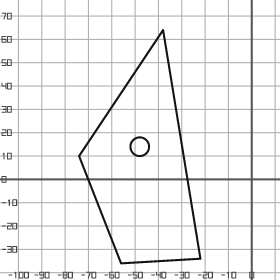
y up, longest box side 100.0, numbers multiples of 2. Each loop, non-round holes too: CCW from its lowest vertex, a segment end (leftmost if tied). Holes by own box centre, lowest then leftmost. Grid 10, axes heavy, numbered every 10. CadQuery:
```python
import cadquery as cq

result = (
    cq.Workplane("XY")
    .moveTo(-56.0, -36.0)
    .lineTo(-22.0, -34.0)
    .lineTo(-38.0, 64.0)
    .lineTo(-74.0, 10.0)
    .close()
    .moveTo(-48.0, 14.0)
    .circle(4.0)
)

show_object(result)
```